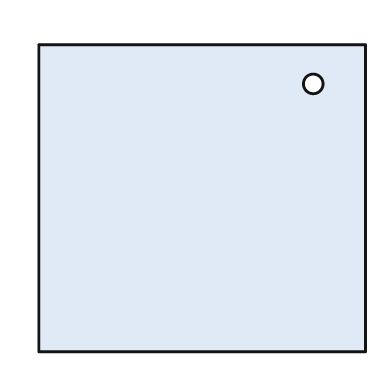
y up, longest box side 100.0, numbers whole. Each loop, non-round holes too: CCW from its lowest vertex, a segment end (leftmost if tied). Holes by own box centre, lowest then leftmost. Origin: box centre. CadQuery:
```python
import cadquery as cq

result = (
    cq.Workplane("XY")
    .moveTo(-50.0, -47.0)
    .lineTo(50.0, -47.0)
    .lineTo(50.0, 47.0)
    .lineTo(-50.0, 47.0)
    .close()
    .moveTo(34.0, 35.0)
    .circle(3.0)
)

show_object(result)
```